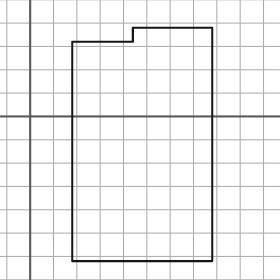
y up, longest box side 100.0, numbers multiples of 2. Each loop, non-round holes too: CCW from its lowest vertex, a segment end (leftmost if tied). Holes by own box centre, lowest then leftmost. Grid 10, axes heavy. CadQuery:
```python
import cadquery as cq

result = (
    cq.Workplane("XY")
    .moveTo(18.0, -62.0)
    .lineTo(78.0, -62.0)
    .lineTo(78.0, 38.0)
    .lineTo(44.0, 38.0)
    .lineTo(44.0, 32.0)
    .lineTo(18.0, 32.0)
    .close()
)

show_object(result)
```